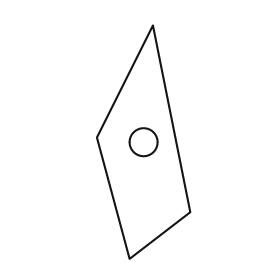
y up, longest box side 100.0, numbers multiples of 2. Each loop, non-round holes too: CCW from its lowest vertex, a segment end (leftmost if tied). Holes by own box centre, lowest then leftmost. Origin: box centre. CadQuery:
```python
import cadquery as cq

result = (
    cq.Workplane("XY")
    .moveTo(-6.0, -50.0)
    .lineTo(20.0, -30.0)
    .lineTo(4.0, 50.0)
    .lineTo(-20.0, 2.0)
    .close()
    .moveTo(0.0, 0.0)
    .circle(6.0)
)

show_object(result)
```